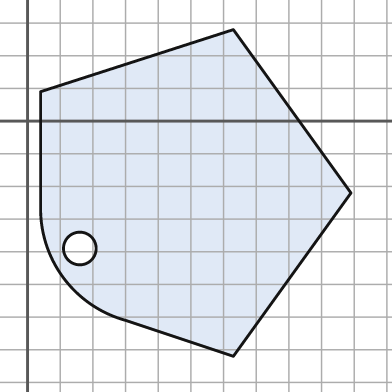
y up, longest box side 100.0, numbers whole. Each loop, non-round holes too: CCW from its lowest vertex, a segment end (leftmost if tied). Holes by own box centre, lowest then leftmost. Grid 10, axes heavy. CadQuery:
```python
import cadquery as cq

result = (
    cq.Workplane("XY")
    .moveTo(63.0, -72.0)
    .lineTo(99.0, -22.0)
    .lineTo(63.0, 28.0)
    .lineTo(4.0, 9.0)
    .lineTo(4.0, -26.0)
    .threePointArc((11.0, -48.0), (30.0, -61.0))
    .close()
    .moveTo(16.0, -39.0)
    .circle(5.0)
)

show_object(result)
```